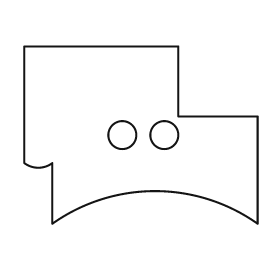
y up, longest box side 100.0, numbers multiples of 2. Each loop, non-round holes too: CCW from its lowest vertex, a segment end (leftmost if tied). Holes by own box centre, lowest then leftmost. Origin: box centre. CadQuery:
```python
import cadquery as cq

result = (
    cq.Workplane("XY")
    .moveTo(-38.0, -38.0)
    .threePointArc((6.0, -24.0), (50.0, -38.0))
    .lineTo(50.0, 8.0)
    .lineTo(16.0, 8.0)
    .lineTo(16.0, 38.0)
    .lineTo(-50.0, 38.0)
    .lineTo(-50.0, -12.0)
    .threePointArc((-44.0, -14.0), (-38.0, -12.0))
    .close()
    .moveTo(-8.0, 0.0)
    .circle(6.0)
    .moveTo(10.0, 0.0)
    .circle(6.0)
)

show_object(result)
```